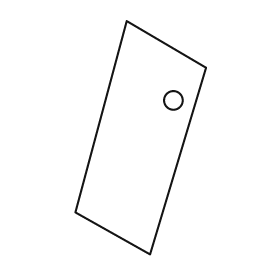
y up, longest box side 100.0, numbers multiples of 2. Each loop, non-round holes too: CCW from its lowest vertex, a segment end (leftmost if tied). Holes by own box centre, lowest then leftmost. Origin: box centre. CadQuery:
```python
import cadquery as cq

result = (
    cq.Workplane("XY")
    .moveTo(4.0, -50.0)
    .lineTo(28.0, 30.0)
    .lineTo(-6.0, 50.0)
    .lineTo(-28.0, -32.0)
    .close()
    .moveTo(14.0, 16.0)
    .circle(4.0)
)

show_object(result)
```